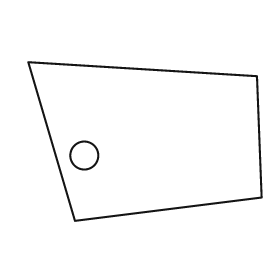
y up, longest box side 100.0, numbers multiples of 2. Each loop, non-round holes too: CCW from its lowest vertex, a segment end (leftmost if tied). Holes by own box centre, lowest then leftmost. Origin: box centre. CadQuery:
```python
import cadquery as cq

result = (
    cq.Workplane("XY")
    .moveTo(-30.0, -34.0)
    .lineTo(50.0, -24.0)
    .lineTo(48.0, 28.0)
    .lineTo(-50.0, 34.0)
    .close()
    .moveTo(-26.0, -6.0)
    .circle(6.0)
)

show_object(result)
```